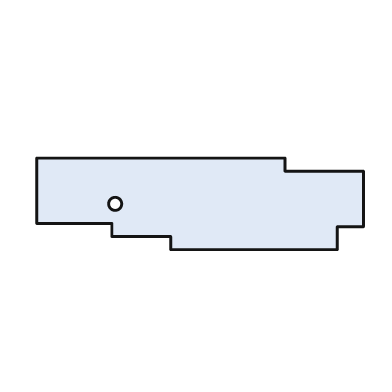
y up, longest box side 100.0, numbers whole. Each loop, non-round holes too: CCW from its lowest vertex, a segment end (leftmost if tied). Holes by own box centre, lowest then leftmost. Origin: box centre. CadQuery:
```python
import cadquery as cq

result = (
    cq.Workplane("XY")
    .moveTo(-9.0, -14.0)
    .lineTo(42.0, -14.0)
    .lineTo(42.0, -7.0)
    .lineTo(50.0, -7.0)
    .lineTo(50.0, 10.0)
    .lineTo(26.0, 10.0)
    .lineTo(26.0, 14.0)
    .lineTo(-50.0, 14.0)
    .lineTo(-50.0, -6.0)
    .lineTo(-27.0, -6.0)
    .lineTo(-27.0, -10.0)
    .lineTo(-9.0, -10.0)
    .close()
    .moveTo(-26.0, 0.0)
    .circle(2.0)
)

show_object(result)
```